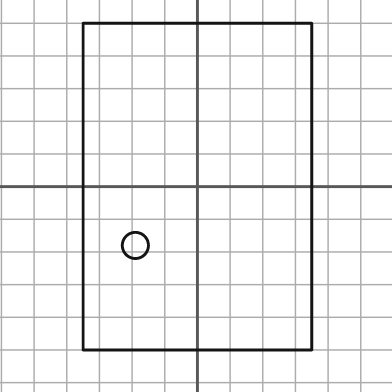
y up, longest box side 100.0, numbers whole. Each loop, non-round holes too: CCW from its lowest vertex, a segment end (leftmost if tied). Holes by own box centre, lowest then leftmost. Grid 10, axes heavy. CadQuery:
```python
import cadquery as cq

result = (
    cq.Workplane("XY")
    .moveTo(-35.0, -50.0)
    .lineTo(35.0, -50.0)
    .lineTo(35.0, 50.0)
    .lineTo(-35.0, 50.0)
    .close()
    .moveTo(-19.0, -18.0)
    .circle(4.0)
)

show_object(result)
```